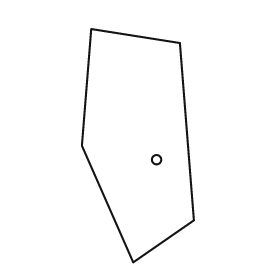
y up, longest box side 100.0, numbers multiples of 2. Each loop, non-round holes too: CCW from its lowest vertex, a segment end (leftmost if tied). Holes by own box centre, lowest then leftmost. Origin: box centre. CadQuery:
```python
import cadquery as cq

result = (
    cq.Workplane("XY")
    .moveTo(-2.0, -50.0)
    .lineTo(24.0, -32.0)
    .lineTo(18.0, 44.0)
    .lineTo(-20.0, 50.0)
    .lineTo(-24.0, 0.0)
    .close()
    .moveTo(8.0, -6.0)
    .circle(2.0)
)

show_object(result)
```